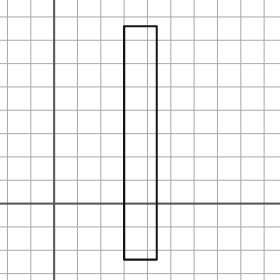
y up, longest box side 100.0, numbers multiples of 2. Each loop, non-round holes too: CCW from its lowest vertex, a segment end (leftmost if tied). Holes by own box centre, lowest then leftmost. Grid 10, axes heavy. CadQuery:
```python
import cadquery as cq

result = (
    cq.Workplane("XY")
    .moveTo(30.0, -24.0)
    .lineTo(44.0, -24.0)
    .lineTo(44.0, 76.0)
    .lineTo(30.0, 76.0)
    .close()
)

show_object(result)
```